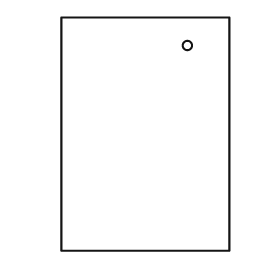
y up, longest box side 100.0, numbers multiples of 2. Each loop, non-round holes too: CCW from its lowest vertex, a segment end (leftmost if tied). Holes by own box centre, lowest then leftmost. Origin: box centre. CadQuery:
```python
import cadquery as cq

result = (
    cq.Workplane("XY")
    .moveTo(-36.0, -50.0)
    .lineTo(36.0, -50.0)
    .lineTo(36.0, 50.0)
    .lineTo(-36.0, 50.0)
    .close()
    .moveTo(18.0, 38.0)
    .circle(2.0)
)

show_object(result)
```